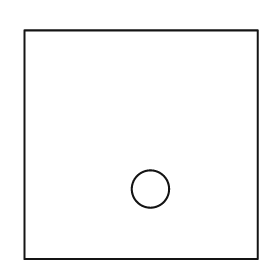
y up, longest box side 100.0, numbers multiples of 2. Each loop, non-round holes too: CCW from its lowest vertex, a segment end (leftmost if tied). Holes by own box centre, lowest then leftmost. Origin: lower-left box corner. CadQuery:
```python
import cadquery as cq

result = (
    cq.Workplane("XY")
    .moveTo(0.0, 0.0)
    .lineTo(100.0, 0.0)
    .lineTo(100.0, 98.0)
    .lineTo(0.0, 98.0)
    .close()
    .moveTo(54.0, 30.0)
    .circle(8.0)
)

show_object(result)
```